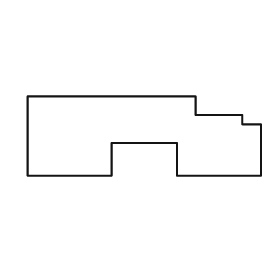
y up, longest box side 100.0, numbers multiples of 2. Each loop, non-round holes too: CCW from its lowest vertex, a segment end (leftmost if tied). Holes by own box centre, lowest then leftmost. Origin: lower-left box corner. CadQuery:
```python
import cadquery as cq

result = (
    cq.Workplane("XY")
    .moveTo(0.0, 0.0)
    .lineTo(36.0, 0.0)
    .lineTo(36.0, 14.0)
    .lineTo(64.0, 14.0)
    .lineTo(64.0, 0.0)
    .lineTo(100.0, 0.0)
    .lineTo(100.0, 22.0)
    .lineTo(92.0, 22.0)
    .lineTo(92.0, 26.0)
    .lineTo(72.0, 26.0)
    .lineTo(72.0, 34.0)
    .lineTo(0.0, 34.0)
    .close()
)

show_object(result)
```